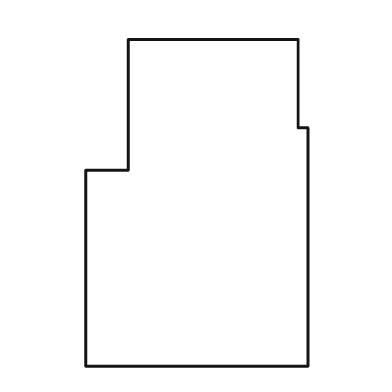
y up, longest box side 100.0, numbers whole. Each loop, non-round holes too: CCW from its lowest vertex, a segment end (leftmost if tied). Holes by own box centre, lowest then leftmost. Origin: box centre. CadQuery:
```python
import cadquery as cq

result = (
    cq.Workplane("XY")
    .moveTo(-34.0, -50.0)
    .lineTo(34.0, -50.0)
    .lineTo(34.0, 23.0)
    .lineTo(31.0, 23.0)
    .lineTo(31.0, 50.0)
    .lineTo(-21.0, 50.0)
    .lineTo(-21.0, 10.0)
    .lineTo(-34.0, 10.0)
    .close()
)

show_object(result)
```